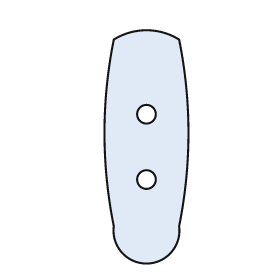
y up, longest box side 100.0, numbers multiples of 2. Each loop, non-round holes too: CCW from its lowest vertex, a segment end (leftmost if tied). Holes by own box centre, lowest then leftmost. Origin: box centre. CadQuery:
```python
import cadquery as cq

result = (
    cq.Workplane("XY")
    .moveTo(-14.0, -34.0)
    .threePointArc((0.0, -50.0), (14.0, -34.0))
    .threePointArc((18.0, 6.0), (14.0, 46.0))
    .threePointArc((0.0, 50.0), (-14.0, 46.0))
    .threePointArc((-18.0, 6.0), (-14.0, -34.0))
    .close()
    .moveTo(0.0, -14.0)
    .circle(4.0)
    .moveTo(0.0, 14.0)
    .circle(4.0)
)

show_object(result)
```